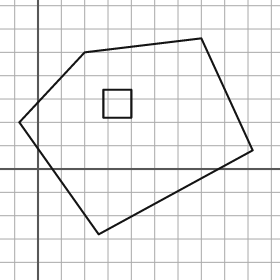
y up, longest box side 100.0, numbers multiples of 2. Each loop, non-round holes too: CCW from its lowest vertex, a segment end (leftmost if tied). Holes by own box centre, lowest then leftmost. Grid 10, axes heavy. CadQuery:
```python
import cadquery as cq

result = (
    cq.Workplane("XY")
    .moveTo(26.0, -28.0)
    .lineTo(92.0, 8.0)
    .lineTo(70.0, 56.0)
    .lineTo(20.0, 50.0)
    .lineTo(-8.0, 20.0)
    .close()
    .moveTo(28.0, 22.0)
    .lineTo(40.0, 22.0)
    .lineTo(40.0, 34.0)
    .lineTo(28.0, 34.0)
    .close()
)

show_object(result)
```